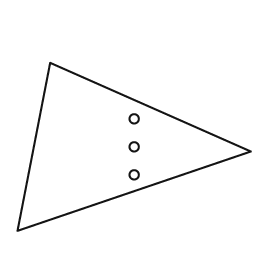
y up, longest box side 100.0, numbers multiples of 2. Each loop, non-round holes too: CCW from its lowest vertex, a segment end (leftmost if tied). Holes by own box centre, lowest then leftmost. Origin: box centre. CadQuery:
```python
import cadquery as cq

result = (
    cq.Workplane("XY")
    .moveTo(-50.0, -36.0)
    .lineTo(50.0, -2.0)
    .lineTo(-36.0, 36.0)
    .close()
    .moveTo(0.0, -12.0)
    .circle(2.0)
    .moveTo(0.0, 0.0)
    .circle(2.0)
    .moveTo(0.0, 12.0)
    .circle(2.0)
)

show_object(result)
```